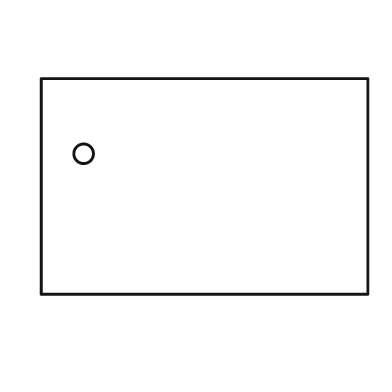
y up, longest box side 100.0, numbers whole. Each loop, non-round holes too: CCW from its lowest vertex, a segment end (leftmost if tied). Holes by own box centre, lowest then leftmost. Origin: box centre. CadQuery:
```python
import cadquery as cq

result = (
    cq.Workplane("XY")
    .moveTo(-50.0, -33.0)
    .lineTo(50.0, -33.0)
    .lineTo(50.0, 33.0)
    .lineTo(-50.0, 33.0)
    .close()
    .moveTo(-37.0, 10.0)
    .circle(3.0)
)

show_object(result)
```